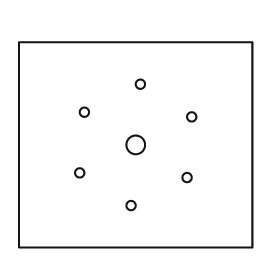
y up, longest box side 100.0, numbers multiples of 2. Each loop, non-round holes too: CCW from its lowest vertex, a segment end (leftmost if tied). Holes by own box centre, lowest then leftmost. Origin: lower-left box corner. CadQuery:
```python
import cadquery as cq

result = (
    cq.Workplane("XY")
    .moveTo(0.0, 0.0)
    .lineTo(100.0, 0.0)
    .lineTo(100.0, 88.0)
    .lineTo(0.0, 88.0)
    .close()
    .moveTo(48.0, 18.0)
    .circle(2.0)
    .moveTo(72.0, 30.0)
    .circle(2.0)
    .moveTo(26.0, 32.0)
    .circle(2.0)
    .moveTo(50.0, 44.0)
    .circle(4.0)
    .moveTo(74.0, 56.0)
    .circle(2.0)
    .moveTo(28.0, 58.0)
    .circle(2.0)
    .moveTo(52.0, 70.0)
    .circle(2.0)
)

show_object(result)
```